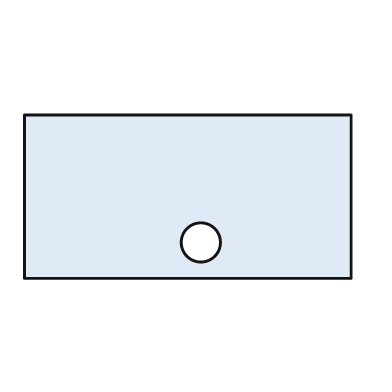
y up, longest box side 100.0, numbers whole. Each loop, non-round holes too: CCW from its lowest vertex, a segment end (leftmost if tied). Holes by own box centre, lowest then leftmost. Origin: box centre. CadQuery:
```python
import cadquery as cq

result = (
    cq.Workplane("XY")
    .moveTo(-50.0, -25.0)
    .lineTo(50.0, -25.0)
    .lineTo(50.0, 25.0)
    .lineTo(-50.0, 25.0)
    .close()
    .moveTo(4.0, -14.0)
    .circle(6.0)
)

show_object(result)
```